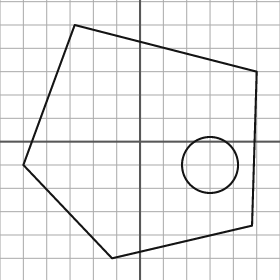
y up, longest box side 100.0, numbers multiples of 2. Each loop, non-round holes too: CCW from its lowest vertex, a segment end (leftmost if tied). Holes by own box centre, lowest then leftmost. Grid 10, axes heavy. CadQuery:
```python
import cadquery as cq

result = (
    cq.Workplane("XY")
    .moveTo(-12.0, -50.0)
    .lineTo(48.0, -36.0)
    .lineTo(50.0, 30.0)
    .lineTo(-28.0, 50.0)
    .lineTo(-50.0, -10.0)
    .close()
    .moveTo(30.0, -10.0)
    .circle(12.0)
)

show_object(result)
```